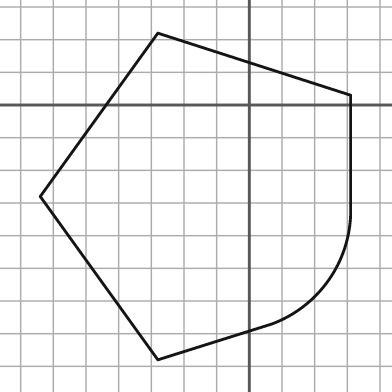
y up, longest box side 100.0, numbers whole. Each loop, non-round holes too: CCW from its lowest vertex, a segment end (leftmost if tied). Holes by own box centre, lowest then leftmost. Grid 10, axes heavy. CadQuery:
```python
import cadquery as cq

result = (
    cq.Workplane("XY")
    .moveTo(-28.0, -78.0)
    .lineTo(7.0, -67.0)
    .threePointArc((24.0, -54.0), (31.0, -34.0))
    .lineTo(31.0, 3.0)
    .lineTo(-28.0, 22.0)
    .lineTo(-64.0, -28.0)
    .close()
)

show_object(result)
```